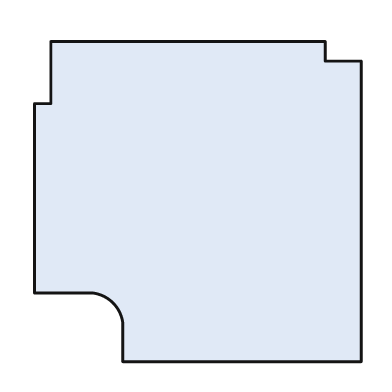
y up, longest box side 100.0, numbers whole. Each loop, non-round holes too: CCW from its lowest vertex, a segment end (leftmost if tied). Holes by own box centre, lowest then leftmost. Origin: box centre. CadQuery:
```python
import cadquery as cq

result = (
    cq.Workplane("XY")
    .moveTo(-23.0, -49.0)
    .lineTo(50.0, -49.0)
    .lineTo(50.0, 43.0)
    .lineTo(39.0, 43.0)
    .lineTo(39.0, 49.0)
    .lineTo(-45.0, 49.0)
    .lineTo(-45.0, 30.0)
    .lineTo(-50.0, 30.0)
    .lineTo(-50.0, -28.0)
    .lineTo(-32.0, -28.0)
    .threePointArc((-26.0, -31.0), (-23.0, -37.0))
    .close()
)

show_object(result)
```